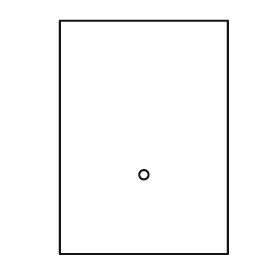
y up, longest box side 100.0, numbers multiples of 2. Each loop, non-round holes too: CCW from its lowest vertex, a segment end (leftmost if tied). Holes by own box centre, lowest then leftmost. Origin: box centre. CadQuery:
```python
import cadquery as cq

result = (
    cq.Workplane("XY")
    .moveTo(-36.0, -50.0)
    .lineTo(36.0, -50.0)
    .lineTo(36.0, 50.0)
    .lineTo(-36.0, 50.0)
    .close()
    .moveTo(0.0, -16.0)
    .circle(2.0)
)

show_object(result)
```